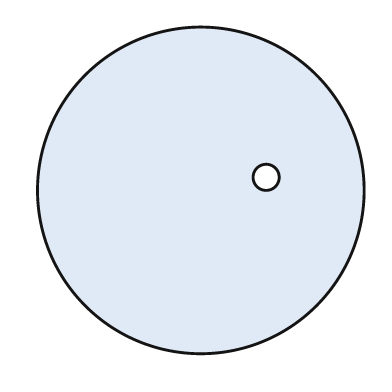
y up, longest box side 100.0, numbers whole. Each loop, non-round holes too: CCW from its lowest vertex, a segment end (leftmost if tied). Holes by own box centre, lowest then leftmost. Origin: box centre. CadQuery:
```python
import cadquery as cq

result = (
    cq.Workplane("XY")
    .moveTo(0.0, 0.0)
    .circle(50.0)
    .moveTo(20.0, 4.0)
    .circle(4.0)
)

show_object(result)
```